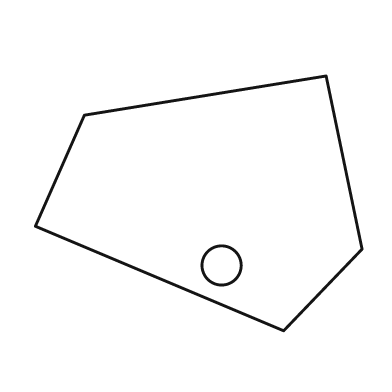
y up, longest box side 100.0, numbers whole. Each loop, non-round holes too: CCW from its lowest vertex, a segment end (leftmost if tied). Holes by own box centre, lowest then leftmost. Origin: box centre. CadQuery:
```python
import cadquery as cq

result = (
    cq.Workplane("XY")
    .moveTo(26.0, -39.0)
    .lineTo(50.0, -14.0)
    .lineTo(39.0, 39.0)
    .lineTo(-35.0, 27.0)
    .lineTo(-50.0, -7.0)
    .close()
    .moveTo(7.0, -19.0)
    .circle(6.0)
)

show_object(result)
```